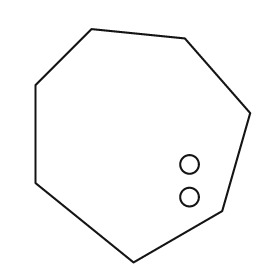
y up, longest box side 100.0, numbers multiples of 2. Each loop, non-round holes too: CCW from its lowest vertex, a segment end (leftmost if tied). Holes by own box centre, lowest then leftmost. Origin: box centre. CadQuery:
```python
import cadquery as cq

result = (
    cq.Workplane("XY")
    .moveTo(-4.0, -50.0)
    .lineTo(34.0, -28.0)
    .lineTo(46.0, 14.0)
    .lineTo(18.0, 46.0)
    .lineTo(-22.0, 50.0)
    .lineTo(-46.0, 26.0)
    .lineTo(-46.0, -16.0)
    .close()
    .moveTo(20.0, -22.0)
    .circle(4.0)
    .moveTo(20.0, -8.0)
    .circle(4.0)
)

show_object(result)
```